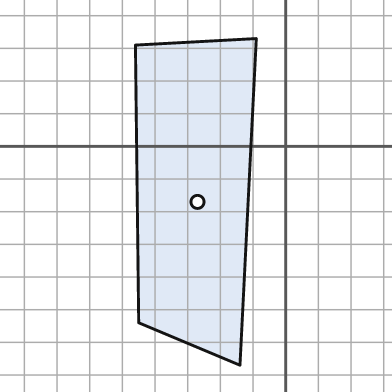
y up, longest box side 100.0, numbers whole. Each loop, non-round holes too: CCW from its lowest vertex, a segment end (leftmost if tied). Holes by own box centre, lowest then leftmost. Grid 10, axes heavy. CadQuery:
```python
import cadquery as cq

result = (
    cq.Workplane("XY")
    .moveTo(-14.0, -67.0)
    .lineTo(-9.0, 33.0)
    .lineTo(-46.0, 31.0)
    .lineTo(-45.0, -54.0)
    .close()
    .moveTo(-27.0, -17.0)
    .circle(2.0)
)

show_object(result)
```